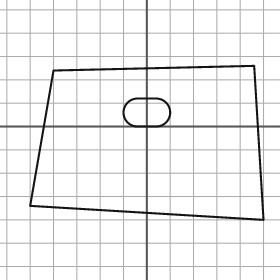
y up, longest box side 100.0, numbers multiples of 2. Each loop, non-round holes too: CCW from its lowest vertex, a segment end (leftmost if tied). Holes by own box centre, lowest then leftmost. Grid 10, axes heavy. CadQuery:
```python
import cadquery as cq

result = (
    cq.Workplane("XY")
    .moveTo(50.0, -40.0)
    .lineTo(46.0, 26.0)
    .lineTo(-40.0, 24.0)
    .lineTo(-50.0, -34.0)
    .close()
    .moveTo(-4.0, 0.0)
    .lineTo(4.0, 0.0)
    .threePointArc((10.0, 6.0), (4.0, 12.0))
    .lineTo(-4.0, 12.0)
    .threePointArc((-10.0, 6.0), (-4.0, 0.0))
    .close()
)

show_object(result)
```